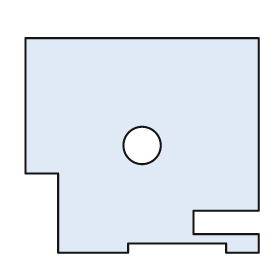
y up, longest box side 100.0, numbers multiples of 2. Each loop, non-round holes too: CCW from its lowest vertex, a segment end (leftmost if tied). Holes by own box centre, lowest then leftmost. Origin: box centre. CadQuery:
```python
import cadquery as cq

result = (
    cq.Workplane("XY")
    .moveTo(-36.0, -46.0)
    .lineTo(-6.0, -46.0)
    .lineTo(-6.0, -42.0)
    .lineTo(36.0, -42.0)
    .lineTo(36.0, -46.0)
    .lineTo(50.0, -46.0)
    .lineTo(50.0, -38.0)
    .lineTo(22.0, -38.0)
    .lineTo(22.0, -28.0)
    .lineTo(50.0, -28.0)
    .lineTo(50.0, 46.0)
    .lineTo(-50.0, 46.0)
    .lineTo(-50.0, -12.0)
    .lineTo(-36.0, -12.0)
    .close()
    .moveTo(0.0, 0.0)
    .circle(8.0)
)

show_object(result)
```